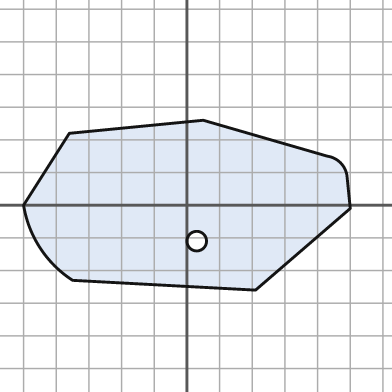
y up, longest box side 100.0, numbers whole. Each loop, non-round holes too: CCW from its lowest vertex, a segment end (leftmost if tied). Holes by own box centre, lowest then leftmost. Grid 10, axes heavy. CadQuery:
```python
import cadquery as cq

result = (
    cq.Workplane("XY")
    .moveTo(21.0, -26.0)
    .lineTo(50.0, -1.0)
    .lineTo(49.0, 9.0)
    .threePointArc((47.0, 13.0), (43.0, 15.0))
    .lineTo(5.0, 26.0)
    .lineTo(-36.0, 22.0)
    .lineTo(-50.0, 0.0)
    .threePointArc((-45.0, -13.0), (-35.0, -23.0))
    .close()
    .moveTo(3.0, -11.0)
    .circle(3.0)
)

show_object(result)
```